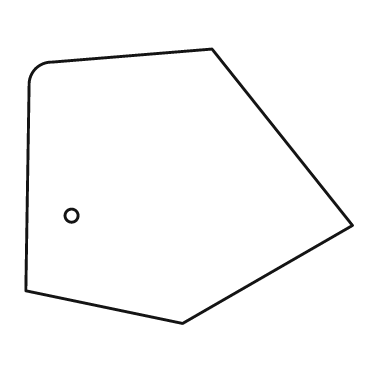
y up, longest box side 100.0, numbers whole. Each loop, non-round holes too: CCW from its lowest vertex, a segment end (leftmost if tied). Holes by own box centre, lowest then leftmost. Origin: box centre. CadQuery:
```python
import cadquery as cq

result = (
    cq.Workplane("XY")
    .moveTo(-2.0, -42.0)
    .lineTo(50.0, -12.0)
    .lineTo(7.0, 42.0)
    .lineTo(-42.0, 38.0)
    .threePointArc((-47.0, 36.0), (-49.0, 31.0))
    .lineTo(-50.0, -32.0)
    .close()
    .moveTo(-36.0, -9.0)
    .circle(2.0)
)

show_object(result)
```